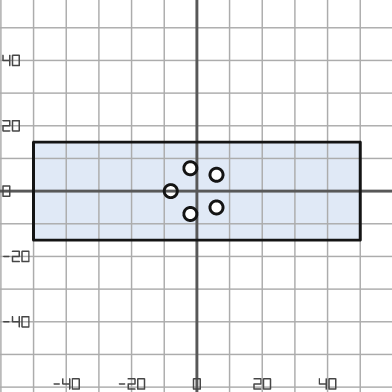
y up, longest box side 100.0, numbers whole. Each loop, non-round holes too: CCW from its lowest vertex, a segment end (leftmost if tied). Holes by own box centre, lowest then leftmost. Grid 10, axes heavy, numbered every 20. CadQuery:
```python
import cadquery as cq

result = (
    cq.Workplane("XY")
    .moveTo(-50.0, -15.0)
    .lineTo(50.0, -15.0)
    .lineTo(50.0, 15.0)
    .lineTo(-50.0, 15.0)
    .close()
    .moveTo(-2.0, -7.0)
    .circle(2.0)
    .moveTo(6.0, -5.0)
    .circle(2.0)
    .moveTo(-8.0, 0.0)
    .circle(2.0)
    .moveTo(6.0, 5.0)
    .circle(2.0)
    .moveTo(-2.0, 7.0)
    .circle(2.0)
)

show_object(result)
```